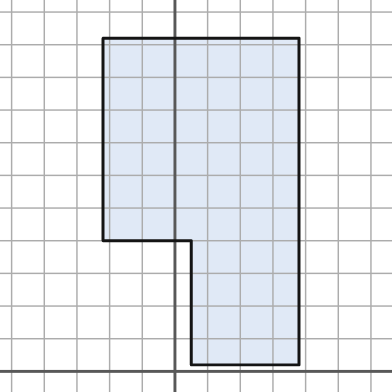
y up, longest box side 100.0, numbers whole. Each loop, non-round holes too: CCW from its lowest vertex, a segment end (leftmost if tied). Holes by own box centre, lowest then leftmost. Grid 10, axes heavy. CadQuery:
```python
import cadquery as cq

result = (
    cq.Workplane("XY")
    .moveTo(5.0, 2.0)
    .lineTo(38.0, 2.0)
    .lineTo(38.0, 102.0)
    .lineTo(-22.0, 102.0)
    .lineTo(-22.0, 40.0)
    .lineTo(5.0, 40.0)
    .close()
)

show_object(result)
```